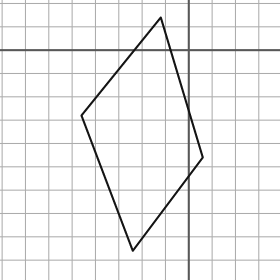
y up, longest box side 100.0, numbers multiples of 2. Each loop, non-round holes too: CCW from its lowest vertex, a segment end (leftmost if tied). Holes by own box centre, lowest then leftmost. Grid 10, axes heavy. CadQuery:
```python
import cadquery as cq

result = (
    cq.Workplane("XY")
    .moveTo(-24.0, -86.0)
    .lineTo(6.0, -46.0)
    .lineTo(-12.0, 14.0)
    .lineTo(-46.0, -28.0)
    .close()
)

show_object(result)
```